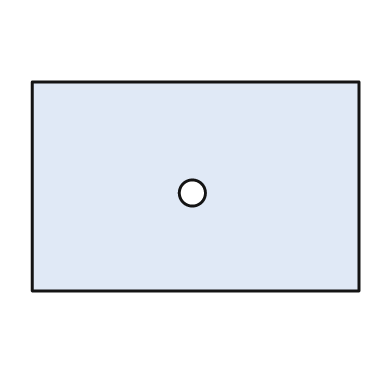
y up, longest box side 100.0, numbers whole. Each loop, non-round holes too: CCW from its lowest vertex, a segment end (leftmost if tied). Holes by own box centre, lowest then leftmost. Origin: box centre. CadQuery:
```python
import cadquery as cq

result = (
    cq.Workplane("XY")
    .moveTo(-50.0, -32.0)
    .lineTo(50.0, -32.0)
    .lineTo(50.0, 32.0)
    .lineTo(-50.0, 32.0)
    .close()
    .moveTo(-1.0, -2.0)
    .circle(4.0)
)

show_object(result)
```